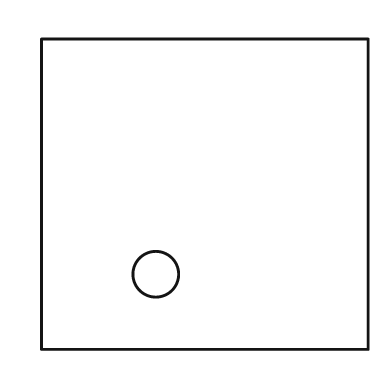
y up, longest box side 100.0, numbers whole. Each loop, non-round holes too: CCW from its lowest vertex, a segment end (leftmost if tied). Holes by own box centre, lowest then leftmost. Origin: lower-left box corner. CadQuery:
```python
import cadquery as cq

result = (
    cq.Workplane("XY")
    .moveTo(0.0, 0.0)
    .lineTo(100.0, 0.0)
    .lineTo(100.0, 95.0)
    .lineTo(0.0, 95.0)
    .close()
    .moveTo(35.0, 23.0)
    .circle(7.0)
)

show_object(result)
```